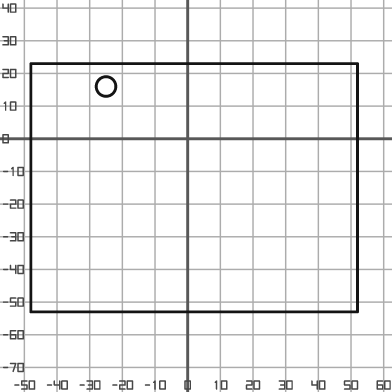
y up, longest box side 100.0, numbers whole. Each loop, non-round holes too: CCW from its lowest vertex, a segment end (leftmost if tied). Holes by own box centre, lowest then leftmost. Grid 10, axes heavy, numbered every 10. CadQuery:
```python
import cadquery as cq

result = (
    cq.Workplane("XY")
    .moveTo(-48.0, -53.0)
    .lineTo(52.0, -53.0)
    .lineTo(52.0, 23.0)
    .lineTo(-48.0, 23.0)
    .close()
    .moveTo(-25.0, 16.0)
    .circle(3.0)
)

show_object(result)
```